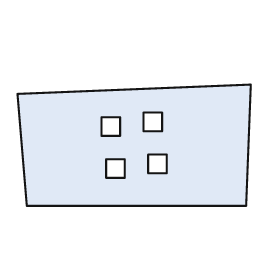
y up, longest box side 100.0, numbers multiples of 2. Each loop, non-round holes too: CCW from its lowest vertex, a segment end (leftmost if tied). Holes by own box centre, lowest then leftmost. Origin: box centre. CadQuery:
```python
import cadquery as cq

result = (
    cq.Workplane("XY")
    .moveTo(-46.0, -26.0)
    .lineTo(48.0, -26.0)
    .lineTo(50.0, 26.0)
    .lineTo(-50.0, 22.0)
    .close()
    .moveTo(-12.0, -14.0)
    .lineTo(-4.0, -14.0)
    .lineTo(-4.0, -6.0)
    .lineTo(-12.0, -6.0)
    .close()
    .moveTo(6.0, -12.0)
    .lineTo(14.0, -12.0)
    .lineTo(14.0, -4.0)
    .lineTo(6.0, -4.0)
    .close()
    .moveTo(-14.0, 4.0)
    .lineTo(-6.0, 4.0)
    .lineTo(-6.0, 12.0)
    .lineTo(-14.0, 12.0)
    .close()
    .moveTo(4.0, 6.0)
    .lineTo(12.0, 6.0)
    .lineTo(12.0, 14.0)
    .lineTo(4.0, 14.0)
    .close()
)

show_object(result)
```